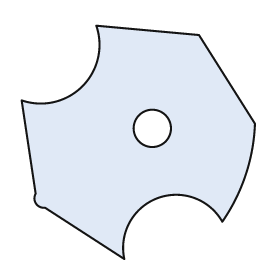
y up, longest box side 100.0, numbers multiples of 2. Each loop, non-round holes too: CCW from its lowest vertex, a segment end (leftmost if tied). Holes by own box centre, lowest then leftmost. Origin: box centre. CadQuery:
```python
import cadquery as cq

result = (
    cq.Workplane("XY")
    .moveTo(-6.0, -50.0)
    .threePointArc((8.0, -24.0), (36.0, -34.0))
    .threePointArc((46.0, -14.0), (50.0, 8.0))
    .lineTo(26.0, 46.0)
    .lineTo(-18.0, 50.0)
    .threePointArc((-24.0, 24.0), (-50.0, 18.0))
    .lineTo(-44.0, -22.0)
    .threePointArc((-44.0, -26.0), (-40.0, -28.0))
    .close()
    .moveTo(6.0, 6.0)
    .circle(8.0)
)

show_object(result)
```